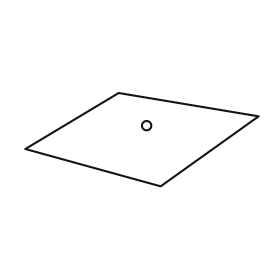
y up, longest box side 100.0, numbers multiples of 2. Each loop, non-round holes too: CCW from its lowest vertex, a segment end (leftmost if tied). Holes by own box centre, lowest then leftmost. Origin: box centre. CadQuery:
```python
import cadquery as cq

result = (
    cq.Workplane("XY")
    .moveTo(8.0, -20.0)
    .lineTo(50.0, 10.0)
    .lineTo(-10.0, 20.0)
    .lineTo(-50.0, -4.0)
    .close()
    .moveTo(2.0, 6.0)
    .circle(2.0)
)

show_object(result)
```